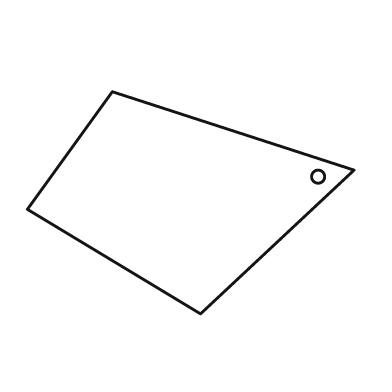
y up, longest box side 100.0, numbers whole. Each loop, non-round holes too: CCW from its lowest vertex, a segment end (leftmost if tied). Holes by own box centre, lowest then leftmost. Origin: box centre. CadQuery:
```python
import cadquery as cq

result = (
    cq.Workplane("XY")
    .moveTo(3.0, -34.0)
    .lineTo(50.0, 10.0)
    .lineTo(-24.0, 34.0)
    .lineTo(-50.0, -2.0)
    .close()
    .moveTo(39.0, 8.0)
    .circle(2.0)
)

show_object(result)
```